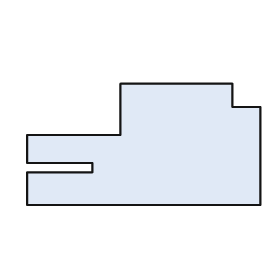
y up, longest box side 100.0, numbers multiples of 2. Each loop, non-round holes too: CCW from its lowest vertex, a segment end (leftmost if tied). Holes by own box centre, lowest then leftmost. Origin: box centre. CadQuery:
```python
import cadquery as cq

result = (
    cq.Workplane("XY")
    .moveTo(-50.0, -26.0)
    .lineTo(50.0, -26.0)
    .lineTo(50.0, 16.0)
    .lineTo(38.0, 16.0)
    .lineTo(38.0, 26.0)
    .lineTo(-10.0, 26.0)
    .lineTo(-10.0, 4.0)
    .lineTo(-50.0, 4.0)
    .lineTo(-50.0, -8.0)
    .lineTo(-22.0, -8.0)
    .lineTo(-22.0, -12.0)
    .lineTo(-50.0, -12.0)
    .close()
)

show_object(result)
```